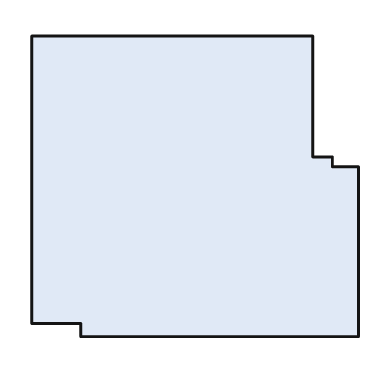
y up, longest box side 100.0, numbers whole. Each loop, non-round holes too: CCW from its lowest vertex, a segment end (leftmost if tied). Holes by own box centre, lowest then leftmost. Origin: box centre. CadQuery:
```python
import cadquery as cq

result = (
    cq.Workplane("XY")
    .moveTo(-35.0, -46.0)
    .lineTo(50.0, -46.0)
    .lineTo(50.0, 6.0)
    .lineTo(42.0, 6.0)
    .lineTo(42.0, 9.0)
    .lineTo(36.0, 9.0)
    .lineTo(36.0, 46.0)
    .lineTo(-50.0, 46.0)
    .lineTo(-50.0, -42.0)
    .lineTo(-35.0, -42.0)
    .close()
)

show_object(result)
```